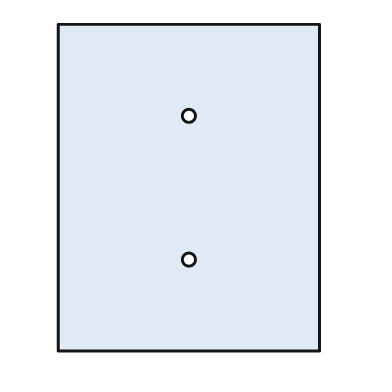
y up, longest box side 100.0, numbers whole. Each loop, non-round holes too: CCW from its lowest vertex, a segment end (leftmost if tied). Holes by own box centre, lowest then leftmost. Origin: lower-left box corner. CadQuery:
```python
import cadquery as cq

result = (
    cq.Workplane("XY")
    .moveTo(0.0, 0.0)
    .lineTo(80.0, 0.0)
    .lineTo(80.0, 100.0)
    .lineTo(0.0, 100.0)
    .close()
    .moveTo(40.0, 28.0)
    .circle(2.0)
    .moveTo(40.0, 72.0)
    .circle(2.0)
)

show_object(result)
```